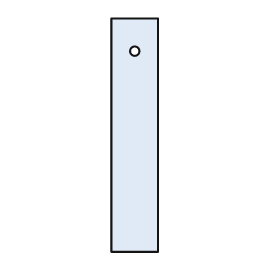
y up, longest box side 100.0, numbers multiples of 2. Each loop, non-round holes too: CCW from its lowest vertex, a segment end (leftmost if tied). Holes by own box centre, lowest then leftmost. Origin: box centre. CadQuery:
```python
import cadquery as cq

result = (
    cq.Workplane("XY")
    .moveTo(-10.0, -50.0)
    .lineTo(10.0, -50.0)
    .lineTo(10.0, 50.0)
    .lineTo(-10.0, 50.0)
    .close()
    .moveTo(0.0, 36.0)
    .circle(2.0)
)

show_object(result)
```